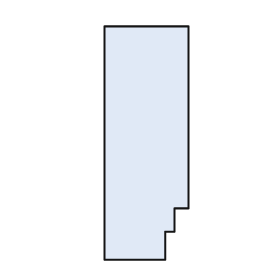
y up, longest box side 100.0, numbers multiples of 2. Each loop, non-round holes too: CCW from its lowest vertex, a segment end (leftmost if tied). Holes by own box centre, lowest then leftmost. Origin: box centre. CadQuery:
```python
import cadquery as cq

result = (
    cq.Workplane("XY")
    .moveTo(-18.0, -50.0)
    .lineTo(8.0, -50.0)
    .lineTo(8.0, -38.0)
    .lineTo(12.0, -38.0)
    .lineTo(12.0, -28.0)
    .lineTo(18.0, -28.0)
    .lineTo(18.0, 50.0)
    .lineTo(-18.0, 50.0)
    .close()
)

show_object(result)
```